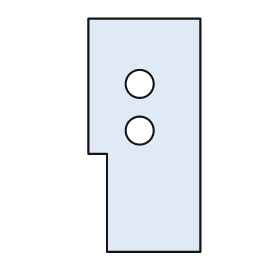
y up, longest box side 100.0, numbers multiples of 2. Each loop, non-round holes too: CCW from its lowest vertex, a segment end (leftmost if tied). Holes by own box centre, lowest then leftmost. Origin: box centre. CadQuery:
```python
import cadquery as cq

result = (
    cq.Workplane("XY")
    .moveTo(-16.0, -50.0)
    .lineTo(24.0, -50.0)
    .lineTo(24.0, 50.0)
    .lineTo(-24.0, 50.0)
    .lineTo(-24.0, -8.0)
    .lineTo(-16.0, -8.0)
    .close()
    .moveTo(-2.0, 2.0)
    .circle(6.0)
    .moveTo(-2.0, 22.0)
    .circle(6.0)
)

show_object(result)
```